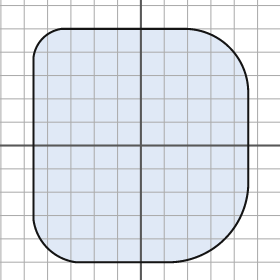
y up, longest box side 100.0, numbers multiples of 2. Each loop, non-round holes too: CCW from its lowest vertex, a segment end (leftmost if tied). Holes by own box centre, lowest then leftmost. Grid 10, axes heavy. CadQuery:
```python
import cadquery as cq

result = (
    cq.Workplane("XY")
    .moveTo(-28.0, -50.0)
    .lineTo(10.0, -50.0)
    .threePointArc((36.0, -40.0), (46.0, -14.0))
    .lineTo(46.0, 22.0)
    .threePointArc((38.0, 42.0), (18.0, 50.0))
    .lineTo(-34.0, 50.0)
    .threePointArc((-42.0, 46.0), (-46.0, 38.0))
    .lineTo(-46.0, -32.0)
    .threePointArc((-40.0, -44.0), (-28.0, -50.0))
    .close()
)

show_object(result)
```